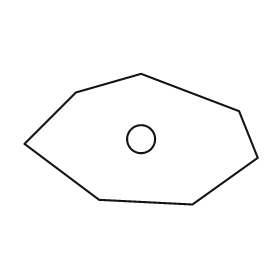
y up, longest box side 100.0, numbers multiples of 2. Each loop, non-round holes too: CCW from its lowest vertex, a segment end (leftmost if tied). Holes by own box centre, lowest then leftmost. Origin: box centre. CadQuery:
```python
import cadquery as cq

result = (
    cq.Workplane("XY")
    .moveTo(22.0, -28.0)
    .lineTo(50.0, -8.0)
    .lineTo(42.0, 12.0)
    .lineTo(0.0, 28.0)
    .lineTo(-28.0, 20.0)
    .lineTo(-50.0, -2.0)
    .lineTo(-18.0, -26.0)
    .close()
    .moveTo(0.0, 0.0)
    .circle(6.0)
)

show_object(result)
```